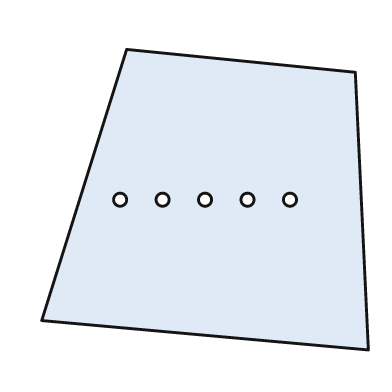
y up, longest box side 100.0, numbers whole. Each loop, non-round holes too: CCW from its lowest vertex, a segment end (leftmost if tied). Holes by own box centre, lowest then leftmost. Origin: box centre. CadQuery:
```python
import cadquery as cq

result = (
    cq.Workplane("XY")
    .moveTo(50.0, -46.0)
    .lineTo(46.0, 39.0)
    .lineTo(-24.0, 46.0)
    .lineTo(-50.0, -37.0)
    .close()
    .moveTo(-26.0, 0.0)
    .circle(2.0)
    .moveTo(-13.0, 0.0)
    .circle(2.0)
    .moveTo(0.0, 0.0)
    .circle(2.0)
    .moveTo(13.0, 0.0)
    .circle(2.0)
    .moveTo(26.0, 0.0)
    .circle(2.0)
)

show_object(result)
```